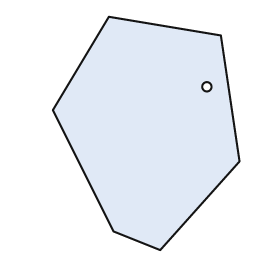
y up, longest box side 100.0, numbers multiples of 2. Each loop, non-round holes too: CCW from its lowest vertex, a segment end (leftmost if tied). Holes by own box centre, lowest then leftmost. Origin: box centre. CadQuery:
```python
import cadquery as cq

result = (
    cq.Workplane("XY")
    .moveTo(6.0, -50.0)
    .lineTo(40.0, -12.0)
    .lineTo(32.0, 42.0)
    .lineTo(-16.0, 50.0)
    .lineTo(-40.0, 10.0)
    .lineTo(-14.0, -42.0)
    .close()
    .moveTo(26.0, 20.0)
    .circle(2.0)
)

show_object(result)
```